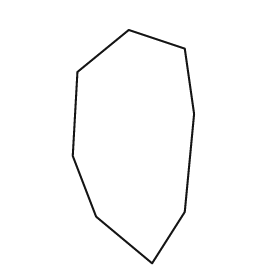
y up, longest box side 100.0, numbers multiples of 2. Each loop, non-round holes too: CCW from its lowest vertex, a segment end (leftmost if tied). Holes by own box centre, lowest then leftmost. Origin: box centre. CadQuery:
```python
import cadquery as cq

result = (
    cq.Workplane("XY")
    .moveTo(8.0, -50.0)
    .lineTo(22.0, -28.0)
    .lineTo(26.0, 14.0)
    .lineTo(22.0, 42.0)
    .lineTo(-2.0, 50.0)
    .lineTo(-24.0, 32.0)
    .lineTo(-26.0, -4.0)
    .lineTo(-16.0, -30.0)
    .close()
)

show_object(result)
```